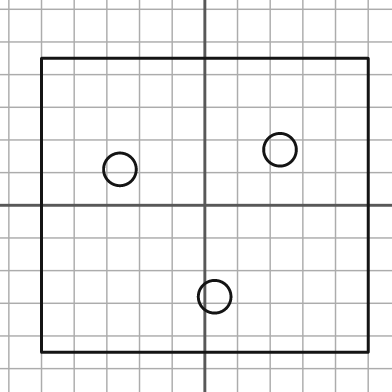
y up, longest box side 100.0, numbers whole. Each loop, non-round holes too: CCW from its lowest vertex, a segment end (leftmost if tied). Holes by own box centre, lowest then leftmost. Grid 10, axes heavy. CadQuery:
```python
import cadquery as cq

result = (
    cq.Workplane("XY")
    .moveTo(-50.0, -45.0)
    .lineTo(50.0, -45.0)
    .lineTo(50.0, 45.0)
    .lineTo(-50.0, 45.0)
    .close()
    .moveTo(3.0, -28.0)
    .circle(5.0)
    .moveTo(-26.0, 11.0)
    .circle(5.0)
    .moveTo(23.0, 17.0)
    .circle(5.0)
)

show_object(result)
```